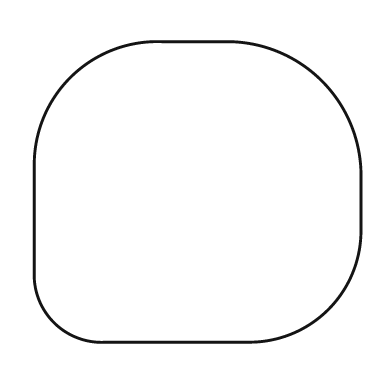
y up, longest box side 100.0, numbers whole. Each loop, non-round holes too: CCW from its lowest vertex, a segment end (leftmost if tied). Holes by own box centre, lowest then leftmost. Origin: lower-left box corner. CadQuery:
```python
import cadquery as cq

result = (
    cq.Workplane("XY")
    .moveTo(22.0, 0.0)
    .lineTo(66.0, 0.0)
    .threePointArc((90.0, 10.0), (100.0, 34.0))
    .lineTo(100.0, 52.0)
    .threePointArc((88.0, 80.0), (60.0, 92.0))
    .lineTo(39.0, 92.0)
    .threePointArc((11.0, 81.0), (0.0, 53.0))
    .lineTo(0.0, 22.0)
    .threePointArc((6.0, 6.0), (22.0, 0.0))
    .close()
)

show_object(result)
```